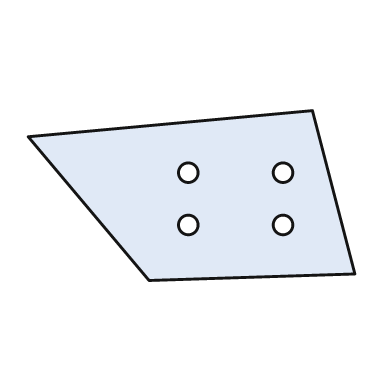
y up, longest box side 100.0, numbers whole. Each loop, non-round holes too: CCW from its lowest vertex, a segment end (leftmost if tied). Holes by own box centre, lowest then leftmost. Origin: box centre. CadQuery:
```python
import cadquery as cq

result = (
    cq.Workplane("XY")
    .moveTo(-13.0, -26.0)
    .lineTo(50.0, -24.0)
    .lineTo(37.0, 26.0)
    .lineTo(-50.0, 18.0)
    .close()
    .moveTo(-1.0, -9.0)
    .circle(3.0)
    .moveTo(28.0, -9.0)
    .circle(3.0)
    .moveTo(-1.0, 7.0)
    .circle(3.0)
    .moveTo(28.0, 7.0)
    .circle(3.0)
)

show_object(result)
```